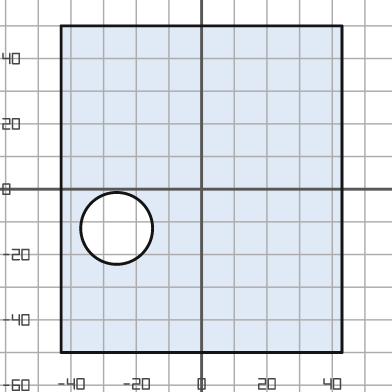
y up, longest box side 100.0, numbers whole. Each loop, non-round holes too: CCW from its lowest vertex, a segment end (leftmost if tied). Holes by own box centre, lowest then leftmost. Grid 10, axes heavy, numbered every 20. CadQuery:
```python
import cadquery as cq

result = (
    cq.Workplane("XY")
    .moveTo(-43.0, -50.0)
    .lineTo(43.0, -50.0)
    .lineTo(43.0, 50.0)
    .lineTo(-43.0, 50.0)
    .close()
    .moveTo(-26.0, -12.0)
    .circle(11.0)
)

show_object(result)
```